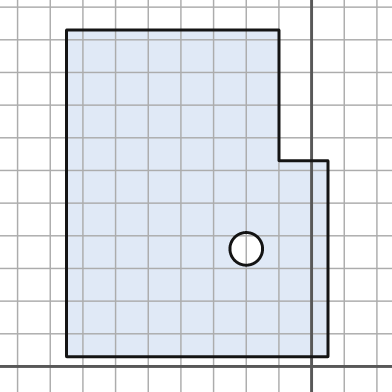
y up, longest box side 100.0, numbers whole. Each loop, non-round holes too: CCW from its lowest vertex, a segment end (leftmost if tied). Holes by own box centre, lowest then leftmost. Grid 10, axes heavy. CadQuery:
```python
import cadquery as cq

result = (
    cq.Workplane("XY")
    .moveTo(-75.0, 3.0)
    .lineTo(5.0, 3.0)
    .lineTo(5.0, 63.0)
    .lineTo(-10.0, 63.0)
    .lineTo(-10.0, 103.0)
    .lineTo(-75.0, 103.0)
    .close()
    .moveTo(-20.0, 36.0)
    .circle(5.0)
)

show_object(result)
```